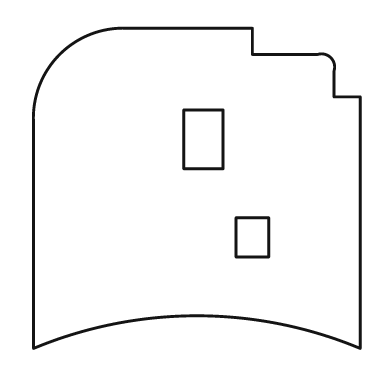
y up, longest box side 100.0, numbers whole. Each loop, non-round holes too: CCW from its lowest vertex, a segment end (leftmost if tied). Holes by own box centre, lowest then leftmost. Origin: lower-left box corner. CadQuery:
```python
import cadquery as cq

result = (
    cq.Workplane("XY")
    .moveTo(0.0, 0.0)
    .threePointArc((50.0, 10.0), (100.0, 0.0))
    .lineTo(100.0, 77.0)
    .lineTo(92.0, 77.0)
    .lineTo(92.0, 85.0)
    .threePointArc((91.0, 89.0), (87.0, 90.0))
    .lineTo(67.0, 90.0)
    .lineTo(67.0, 98.0)
    .lineTo(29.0, 98.0)
    .threePointArc((8.0, 90.0), (0.0, 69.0))
    .close()
    .moveTo(62.0, 28.0)
    .lineTo(72.0, 28.0)
    .lineTo(72.0, 40.0)
    .lineTo(62.0, 40.0)
    .close()
    .moveTo(46.0, 55.0)
    .lineTo(58.0, 55.0)
    .lineTo(58.0, 73.0)
    .lineTo(46.0, 73.0)
    .close()
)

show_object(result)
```